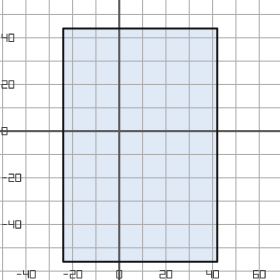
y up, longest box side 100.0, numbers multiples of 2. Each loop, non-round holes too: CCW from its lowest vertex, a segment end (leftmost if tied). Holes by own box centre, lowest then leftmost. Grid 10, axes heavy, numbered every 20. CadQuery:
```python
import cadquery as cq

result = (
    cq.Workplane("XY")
    .moveTo(-24.0, -56.0)
    .lineTo(42.0, -56.0)
    .lineTo(42.0, 44.0)
    .lineTo(-24.0, 44.0)
    .close()
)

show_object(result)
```